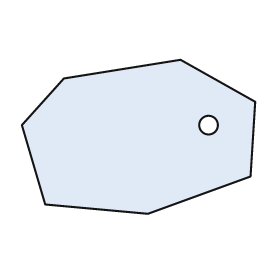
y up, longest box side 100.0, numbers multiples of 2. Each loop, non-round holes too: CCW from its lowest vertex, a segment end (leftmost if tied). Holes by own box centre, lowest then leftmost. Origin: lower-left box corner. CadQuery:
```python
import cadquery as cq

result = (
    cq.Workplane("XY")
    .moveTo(54.0, 0.0)
    .lineTo(98.0, 16.0)
    .lineTo(100.0, 48.0)
    .lineTo(68.0, 66.0)
    .lineTo(18.0, 58.0)
    .lineTo(0.0, 38.0)
    .lineTo(10.0, 4.0)
    .close()
    .moveTo(80.0, 38.0)
    .circle(4.0)
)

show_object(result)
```